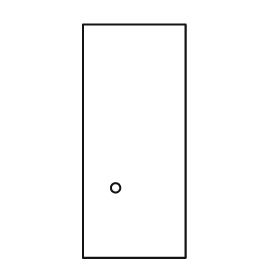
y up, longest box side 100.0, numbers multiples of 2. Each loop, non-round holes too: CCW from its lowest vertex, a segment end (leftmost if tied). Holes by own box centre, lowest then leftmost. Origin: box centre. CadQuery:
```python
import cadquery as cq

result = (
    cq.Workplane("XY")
    .moveTo(-22.0, -50.0)
    .lineTo(22.0, -50.0)
    .lineTo(22.0, 50.0)
    .lineTo(-22.0, 50.0)
    .close()
    .moveTo(-8.0, -20.0)
    .circle(2.0)
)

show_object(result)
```